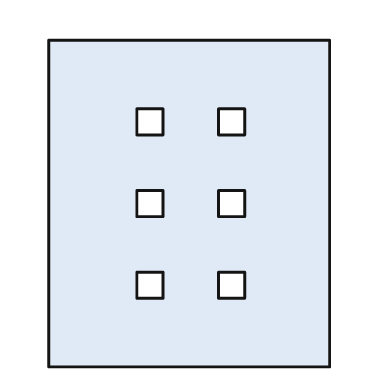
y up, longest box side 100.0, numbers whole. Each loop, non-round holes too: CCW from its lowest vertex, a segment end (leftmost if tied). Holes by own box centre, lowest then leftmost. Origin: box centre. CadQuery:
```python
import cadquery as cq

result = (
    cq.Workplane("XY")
    .moveTo(-43.0, -50.0)
    .lineTo(43.0, -50.0)
    .lineTo(43.0, 50.0)
    .lineTo(-43.0, 50.0)
    .close()
    .moveTo(-16.0, -29.0)
    .lineTo(-8.0, -29.0)
    .lineTo(-8.0, -21.0)
    .lineTo(-16.0, -21.0)
    .close()
    .moveTo(9.0, -29.0)
    .lineTo(17.0, -29.0)
    .lineTo(17.0, -21.0)
    .lineTo(9.0, -21.0)
    .close()
    .moveTo(-16.0, -4.0)
    .lineTo(-8.0, -4.0)
    .lineTo(-8.0, 4.0)
    .lineTo(-16.0, 4.0)
    .close()
    .moveTo(9.0, -4.0)
    .lineTo(17.0, -4.0)
    .lineTo(17.0, 4.0)
    .lineTo(9.0, 4.0)
    .close()
    .moveTo(-16.0, 21.0)
    .lineTo(-8.0, 21.0)
    .lineTo(-8.0, 29.0)
    .lineTo(-16.0, 29.0)
    .close()
    .moveTo(9.0, 21.0)
    .lineTo(17.0, 21.0)
    .lineTo(17.0, 29.0)
    .lineTo(9.0, 29.0)
    .close()
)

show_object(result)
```